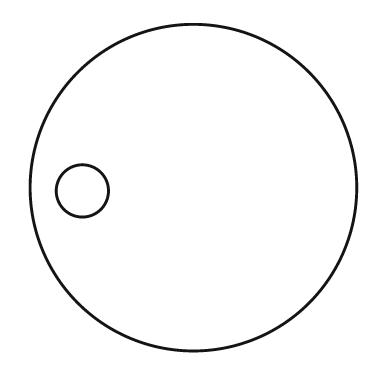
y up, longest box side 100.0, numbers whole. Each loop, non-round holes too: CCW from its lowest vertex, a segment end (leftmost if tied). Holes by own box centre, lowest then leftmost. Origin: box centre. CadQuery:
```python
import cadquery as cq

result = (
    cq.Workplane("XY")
    .moveTo(0.0, 0.0)
    .circle(50.0)
    .moveTo(-34.0, -1.0)
    .circle(8.0)
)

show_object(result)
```